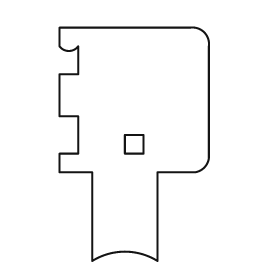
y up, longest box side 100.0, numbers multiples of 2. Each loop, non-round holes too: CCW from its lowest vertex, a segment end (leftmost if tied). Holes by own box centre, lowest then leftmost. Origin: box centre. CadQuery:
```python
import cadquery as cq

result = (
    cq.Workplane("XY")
    .moveTo(-18.0, -50.0)
    .threePointArc((-4.0, -46.0), (10.0, -50.0))
    .lineTo(10.0, -12.0)
    .lineTo(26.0, -12.0)
    .threePointArc((30.0, -10.0), (32.0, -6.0))
    .lineTo(32.0, 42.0)
    .threePointArc((30.0, 48.0), (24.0, 50.0))
    .lineTo(-32.0, 50.0)
    .lineTo(-32.0, 42.0)
    .threePointArc((-28.0, 40.0), (-24.0, 42.0))
    .lineTo(-24.0, 30.0)
    .lineTo(-32.0, 30.0)
    .lineTo(-32.0, 12.0)
    .lineTo(-24.0, 12.0)
    .lineTo(-24.0, -4.0)
    .lineTo(-32.0, -4.0)
    .lineTo(-32.0, -12.0)
    .lineTo(-18.0, -12.0)
    .close()
    .moveTo(-4.0, -4.0)
    .lineTo(4.0, -4.0)
    .lineTo(4.0, 4.0)
    .lineTo(-4.0, 4.0)
    .close()
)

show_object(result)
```